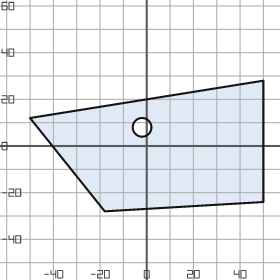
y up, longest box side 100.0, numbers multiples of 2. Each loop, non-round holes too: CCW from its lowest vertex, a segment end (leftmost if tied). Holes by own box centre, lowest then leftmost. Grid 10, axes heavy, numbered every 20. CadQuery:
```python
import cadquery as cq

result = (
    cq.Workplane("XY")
    .moveTo(-18.0, -28.0)
    .lineTo(50.0, -24.0)
    .lineTo(50.0, 28.0)
    .lineTo(-50.0, 12.0)
    .close()
    .moveTo(-2.0, 8.0)
    .circle(4.0)
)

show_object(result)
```